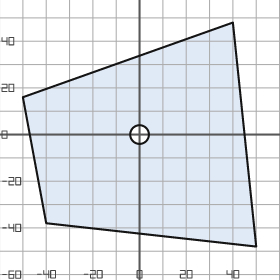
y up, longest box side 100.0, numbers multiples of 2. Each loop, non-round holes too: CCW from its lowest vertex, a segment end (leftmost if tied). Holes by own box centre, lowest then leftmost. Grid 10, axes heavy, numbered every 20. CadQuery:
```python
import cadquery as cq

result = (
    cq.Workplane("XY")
    .moveTo(50.0, -48.0)
    .lineTo(40.0, 48.0)
    .lineTo(-50.0, 16.0)
    .lineTo(-40.0, -38.0)
    .close()
    .moveTo(0.0, 0.0)
    .circle(4.0)
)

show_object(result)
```